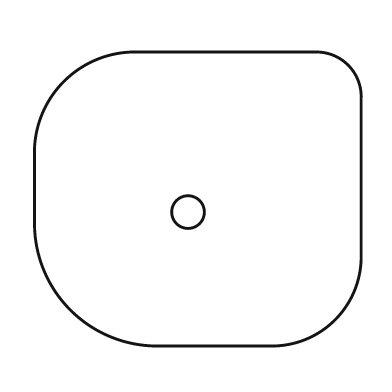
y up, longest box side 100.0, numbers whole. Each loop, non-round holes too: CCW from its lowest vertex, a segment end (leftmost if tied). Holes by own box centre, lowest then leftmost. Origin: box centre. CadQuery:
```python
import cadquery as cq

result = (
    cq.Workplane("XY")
    .moveTo(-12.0, -45.0)
    .lineTo(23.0, -45.0)
    .threePointArc((42.0, -37.0), (50.0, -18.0))
    .lineTo(50.0, 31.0)
    .threePointArc((46.0, 41.0), (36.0, 45.0))
    .lineTo(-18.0, 45.0)
    .threePointArc((-41.0, 36.0), (-50.0, 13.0))
    .lineTo(-50.0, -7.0)
    .threePointArc((-39.0, -34.0), (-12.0, -45.0))
    .close()
    .moveTo(-3.0, -4.0)
    .circle(5.0)
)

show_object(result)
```